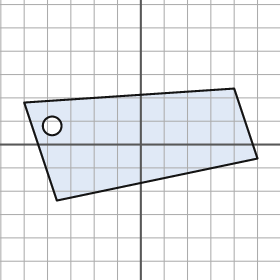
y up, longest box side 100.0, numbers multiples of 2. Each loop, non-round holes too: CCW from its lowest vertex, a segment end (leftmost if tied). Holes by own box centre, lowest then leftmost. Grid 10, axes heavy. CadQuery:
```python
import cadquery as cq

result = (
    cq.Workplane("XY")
    .moveTo(-36.0, -24.0)
    .lineTo(50.0, -6.0)
    .lineTo(40.0, 24.0)
    .lineTo(-50.0, 18.0)
    .close()
    .moveTo(-38.0, 8.0)
    .circle(4.0)
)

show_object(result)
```